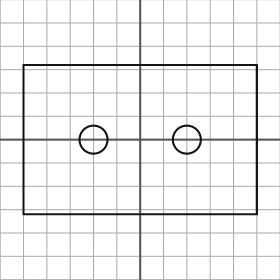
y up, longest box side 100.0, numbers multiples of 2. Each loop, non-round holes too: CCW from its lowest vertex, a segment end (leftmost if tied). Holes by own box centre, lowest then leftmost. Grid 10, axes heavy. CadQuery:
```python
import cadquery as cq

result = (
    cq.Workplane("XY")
    .moveTo(-50.0, -32.0)
    .lineTo(50.0, -32.0)
    .lineTo(50.0, 32.0)
    .lineTo(-50.0, 32.0)
    .close()
    .moveTo(-20.0, 0.0)
    .circle(6.0)
    .moveTo(20.0, 0.0)
    .circle(6.0)
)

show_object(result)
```